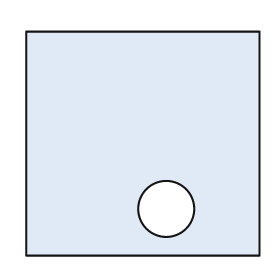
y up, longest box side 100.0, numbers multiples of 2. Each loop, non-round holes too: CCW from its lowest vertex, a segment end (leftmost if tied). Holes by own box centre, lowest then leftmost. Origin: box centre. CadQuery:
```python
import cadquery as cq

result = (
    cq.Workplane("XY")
    .moveTo(-50.0, -48.0)
    .lineTo(50.0, -48.0)
    .lineTo(50.0, 48.0)
    .lineTo(-50.0, 48.0)
    .close()
    .moveTo(10.0, -28.0)
    .circle(12.0)
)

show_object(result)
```